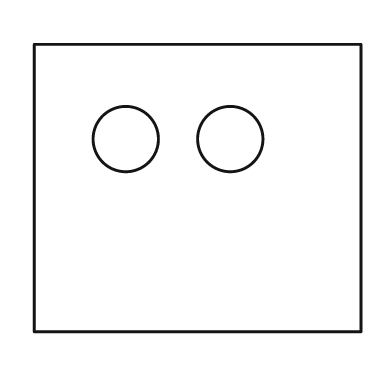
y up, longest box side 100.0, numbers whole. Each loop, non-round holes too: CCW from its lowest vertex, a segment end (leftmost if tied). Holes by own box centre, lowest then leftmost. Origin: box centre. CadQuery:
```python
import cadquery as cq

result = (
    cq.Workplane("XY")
    .moveTo(-50.0, -44.0)
    .lineTo(50.0, -44.0)
    .lineTo(50.0, 44.0)
    .lineTo(-50.0, 44.0)
    .close()
    .moveTo(-22.0, 15.0)
    .circle(10.0)
    .moveTo(10.0, 15.0)
    .circle(10.0)
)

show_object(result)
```